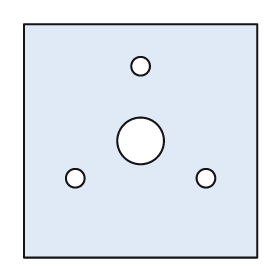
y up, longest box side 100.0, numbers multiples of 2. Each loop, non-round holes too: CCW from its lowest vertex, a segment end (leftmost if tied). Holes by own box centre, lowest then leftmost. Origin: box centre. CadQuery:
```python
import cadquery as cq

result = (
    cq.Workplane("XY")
    .moveTo(-50.0, -50.0)
    .lineTo(50.0, -50.0)
    .lineTo(50.0, 50.0)
    .lineTo(-50.0, 50.0)
    .close()
    .moveTo(-28.0, -16.0)
    .circle(4.0)
    .moveTo(28.0, -16.0)
    .circle(4.0)
    .moveTo(0.0, 0.0)
    .circle(10.0)
    .moveTo(0.0, 32.0)
    .circle(4.0)
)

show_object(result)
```